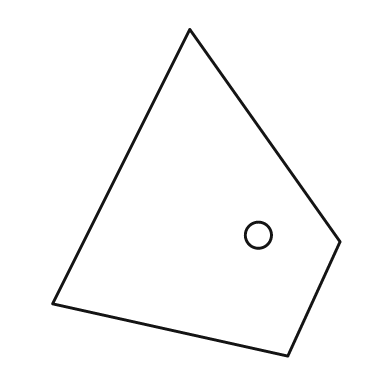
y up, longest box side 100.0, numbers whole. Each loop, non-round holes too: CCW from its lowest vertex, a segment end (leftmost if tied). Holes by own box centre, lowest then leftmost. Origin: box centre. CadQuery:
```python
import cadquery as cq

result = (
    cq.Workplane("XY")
    .moveTo(28.0, -50.0)
    .lineTo(44.0, -15.0)
    .lineTo(-2.0, 50.0)
    .lineTo(-44.0, -34.0)
    .close()
    .moveTo(19.0, -13.0)
    .circle(4.0)
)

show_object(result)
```